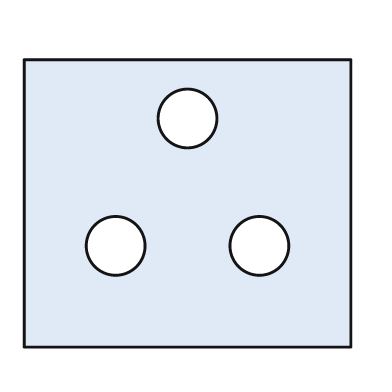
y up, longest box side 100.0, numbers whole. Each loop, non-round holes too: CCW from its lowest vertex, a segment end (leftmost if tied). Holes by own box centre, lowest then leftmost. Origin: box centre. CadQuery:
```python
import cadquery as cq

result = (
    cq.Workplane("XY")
    .moveTo(-50.0, -44.0)
    .lineTo(50.0, -44.0)
    .lineTo(50.0, 44.0)
    .lineTo(-50.0, 44.0)
    .close()
    .moveTo(-22.0, -13.0)
    .circle(9.0)
    .moveTo(22.0, -13.0)
    .circle(9.0)
    .moveTo(0.0, 26.0)
    .circle(9.0)
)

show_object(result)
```